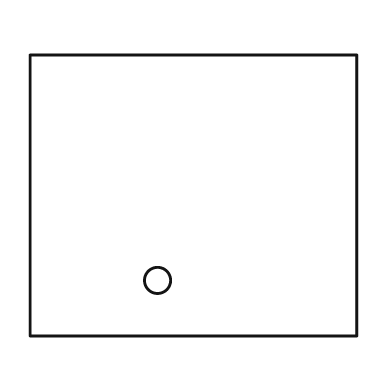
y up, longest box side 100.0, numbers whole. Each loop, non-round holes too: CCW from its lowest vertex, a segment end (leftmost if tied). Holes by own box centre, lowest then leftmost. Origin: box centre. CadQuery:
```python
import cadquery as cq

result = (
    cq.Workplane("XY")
    .moveTo(-50.0, -43.0)
    .lineTo(50.0, -43.0)
    .lineTo(50.0, 43.0)
    .lineTo(-50.0, 43.0)
    .close()
    .moveTo(-11.0, -26.0)
    .circle(4.0)
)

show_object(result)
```